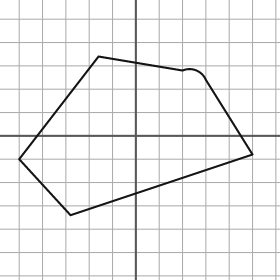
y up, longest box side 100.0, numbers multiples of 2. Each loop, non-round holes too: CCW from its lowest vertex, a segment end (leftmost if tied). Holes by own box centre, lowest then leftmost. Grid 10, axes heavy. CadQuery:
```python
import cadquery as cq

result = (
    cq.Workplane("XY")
    .moveTo(-28.0, -34.0)
    .lineTo(50.0, -8.0)
    .lineTo(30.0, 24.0)
    .threePointArc((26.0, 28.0), (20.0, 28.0))
    .lineTo(-16.0, 34.0)
    .lineTo(-50.0, -10.0)
    .close()
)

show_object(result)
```